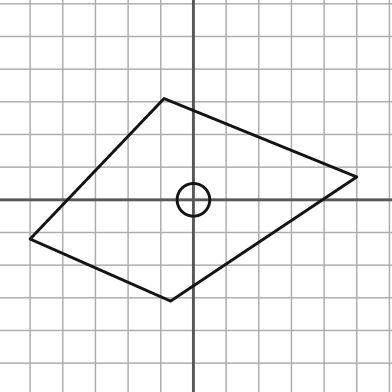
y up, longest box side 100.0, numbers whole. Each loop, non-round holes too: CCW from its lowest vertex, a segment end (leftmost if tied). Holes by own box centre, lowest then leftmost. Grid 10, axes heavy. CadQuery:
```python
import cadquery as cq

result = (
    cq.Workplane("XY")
    .moveTo(-7.0, -31.0)
    .lineTo(50.0, 7.0)
    .lineTo(-9.0, 31.0)
    .lineTo(-50.0, -12.0)
    .close()
    .moveTo(0.0, 0.0)
    .circle(5.0)
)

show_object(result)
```